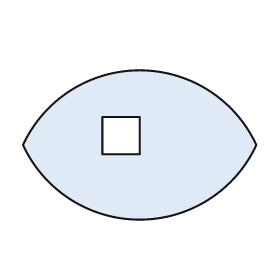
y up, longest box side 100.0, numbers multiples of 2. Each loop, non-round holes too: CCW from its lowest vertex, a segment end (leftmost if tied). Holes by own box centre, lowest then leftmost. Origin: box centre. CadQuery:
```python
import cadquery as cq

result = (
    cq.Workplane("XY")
    .moveTo(-50.0, 0.0)
    .threePointArc((0.0, -32.0), (50.0, 0.0))
    .threePointArc((0.0, 32.0), (-50.0, 0.0))
    .close()
    .moveTo(-16.0, -4.0)
    .lineTo(0.0, -4.0)
    .lineTo(0.0, 12.0)
    .lineTo(-16.0, 12.0)
    .close()
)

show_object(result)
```